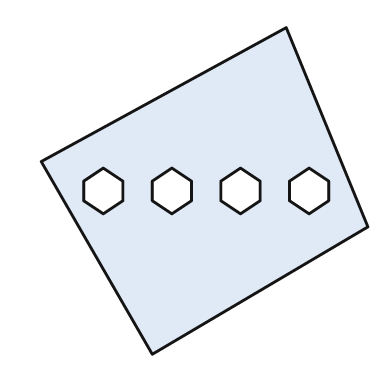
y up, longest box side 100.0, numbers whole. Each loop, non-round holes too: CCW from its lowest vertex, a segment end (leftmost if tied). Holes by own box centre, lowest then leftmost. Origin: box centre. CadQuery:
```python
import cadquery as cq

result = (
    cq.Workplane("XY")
    .moveTo(-16.0, -50.0)
    .lineTo(50.0, -11.0)
    .lineTo(25.0, 50.0)
    .lineTo(-50.0, 9.0)
    .close()
    .moveTo(-31.0, -7.0)
    .lineTo(-25.0, -3.0)
    .lineTo(-25.0, 3.0)
    .lineTo(-31.0, 7.0)
    .lineTo(-37.0, 3.0)
    .lineTo(-37.0, -3.0)
    .close()
    .moveTo(-10.0, -7.0)
    .lineTo(-4.0, -3.0)
    .lineTo(-4.0, 3.0)
    .lineTo(-10.0, 7.0)
    .lineTo(-16.0, 3.0)
    .lineTo(-16.0, -3.0)
    .close()
    .moveTo(11.0, -7.0)
    .lineTo(17.0, -3.0)
    .lineTo(17.0, 3.0)
    .lineTo(11.0, 7.0)
    .lineTo(5.0, 3.0)
    .lineTo(5.0, -3.0)
    .close()
    .moveTo(32.0, -7.0)
    .lineTo(38.0, -3.0)
    .lineTo(38.0, 3.0)
    .lineTo(32.0, 7.0)
    .lineTo(26.0, 3.0)
    .lineTo(26.0, -3.0)
    .close()
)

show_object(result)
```